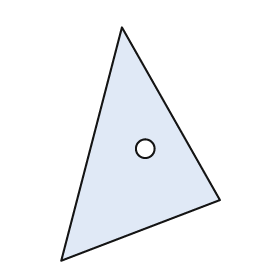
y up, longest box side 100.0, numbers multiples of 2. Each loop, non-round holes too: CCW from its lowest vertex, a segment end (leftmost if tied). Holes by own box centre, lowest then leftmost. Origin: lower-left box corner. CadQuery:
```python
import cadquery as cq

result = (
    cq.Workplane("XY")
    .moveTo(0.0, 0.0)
    .lineTo(68.0, 26.0)
    .lineTo(26.0, 100.0)
    .close()
    .moveTo(36.0, 48.0)
    .circle(4.0)
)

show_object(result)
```